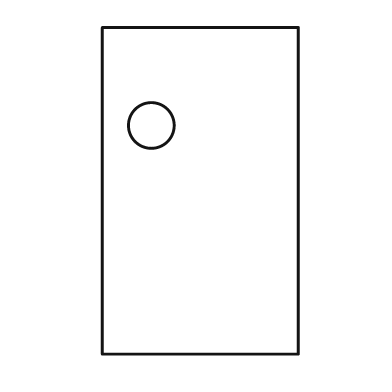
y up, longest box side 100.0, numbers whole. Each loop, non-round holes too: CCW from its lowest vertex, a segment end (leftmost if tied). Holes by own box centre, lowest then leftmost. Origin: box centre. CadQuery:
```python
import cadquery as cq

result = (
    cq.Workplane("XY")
    .moveTo(-30.0, -50.0)
    .lineTo(30.0, -50.0)
    .lineTo(30.0, 50.0)
    .lineTo(-30.0, 50.0)
    .close()
    .moveTo(-15.0, 20.0)
    .circle(7.0)
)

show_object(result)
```